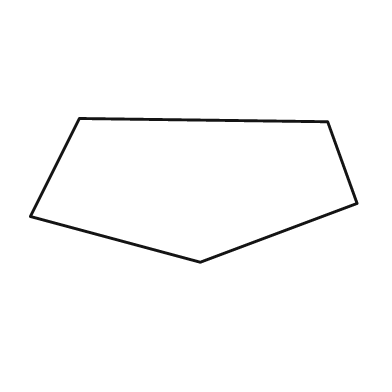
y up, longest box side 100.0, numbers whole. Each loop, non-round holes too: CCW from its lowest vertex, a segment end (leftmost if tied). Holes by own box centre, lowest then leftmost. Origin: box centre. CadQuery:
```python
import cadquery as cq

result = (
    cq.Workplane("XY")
    .moveTo(2.0, -22.0)
    .lineTo(50.0, -4.0)
    .lineTo(41.0, 21.0)
    .lineTo(-35.0, 22.0)
    .lineTo(-50.0, -8.0)
    .close()
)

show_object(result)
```